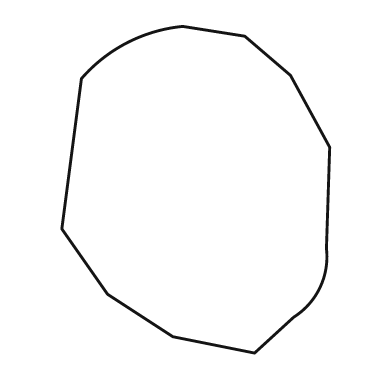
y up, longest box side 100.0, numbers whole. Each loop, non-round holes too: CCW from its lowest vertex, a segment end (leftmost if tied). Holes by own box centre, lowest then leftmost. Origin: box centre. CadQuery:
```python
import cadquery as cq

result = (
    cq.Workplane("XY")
    .moveTo(18.0, -50.0)
    .lineTo(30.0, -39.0)
    .threePointArc((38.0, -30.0), (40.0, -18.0))
    .lineTo(41.0, 13.0)
    .lineTo(29.0, 35.0)
    .lineTo(15.0, 47.0)
    .lineTo(-4.0, 50.0)
    .threePointArc((-21.0, 45.0), (-35.0, 34.0))
    .lineTo(-41.0, -12.0)
    .lineTo(-27.0, -32.0)
    .lineTo(-7.0, -45.0)
    .close()
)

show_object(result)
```